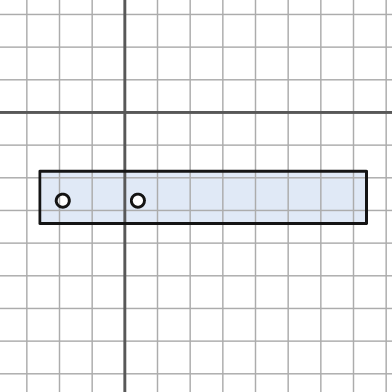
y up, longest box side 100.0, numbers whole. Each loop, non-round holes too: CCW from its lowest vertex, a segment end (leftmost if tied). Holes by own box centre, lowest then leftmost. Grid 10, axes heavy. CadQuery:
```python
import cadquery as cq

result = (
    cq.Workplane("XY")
    .moveTo(-26.0, -34.0)
    .lineTo(74.0, -34.0)
    .lineTo(74.0, -18.0)
    .lineTo(-26.0, -18.0)
    .close()
    .moveTo(-19.0, -27.0)
    .circle(2.0)
    .moveTo(4.0, -27.0)
    .circle(2.0)
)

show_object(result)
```